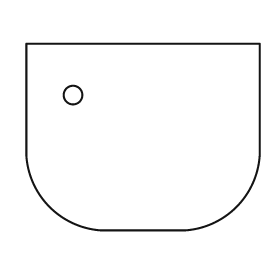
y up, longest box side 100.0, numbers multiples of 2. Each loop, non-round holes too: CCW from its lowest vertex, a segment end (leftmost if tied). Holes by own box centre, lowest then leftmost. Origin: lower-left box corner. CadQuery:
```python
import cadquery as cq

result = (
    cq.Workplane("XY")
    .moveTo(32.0, 0.0)
    .lineTo(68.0, 0.0)
    .threePointArc((90.0, 10.0), (100.0, 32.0))
    .lineTo(100.0, 80.0)
    .lineTo(0.0, 80.0)
    .lineTo(0.0, 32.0)
    .threePointArc((10.0, 10.0), (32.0, 0.0))
    .close()
    .moveTo(20.0, 58.0)
    .circle(4.0)
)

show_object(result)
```